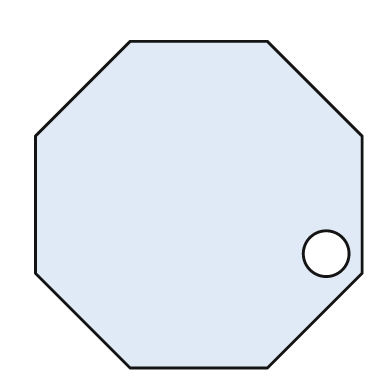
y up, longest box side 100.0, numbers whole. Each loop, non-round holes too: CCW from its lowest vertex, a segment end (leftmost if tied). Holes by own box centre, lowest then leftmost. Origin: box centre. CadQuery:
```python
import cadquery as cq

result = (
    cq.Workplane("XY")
    .moveTo(-21.0, -50.0)
    .lineTo(21.0, -50.0)
    .lineTo(50.0, -21.0)
    .lineTo(50.0, 21.0)
    .lineTo(21.0, 50.0)
    .lineTo(-21.0, 50.0)
    .lineTo(-50.0, 21.0)
    .lineTo(-50.0, -21.0)
    .close()
    .moveTo(39.0, -15.0)
    .circle(7.0)
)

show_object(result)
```